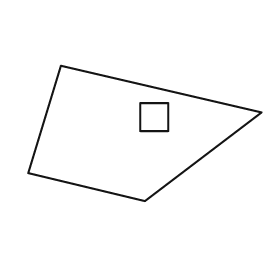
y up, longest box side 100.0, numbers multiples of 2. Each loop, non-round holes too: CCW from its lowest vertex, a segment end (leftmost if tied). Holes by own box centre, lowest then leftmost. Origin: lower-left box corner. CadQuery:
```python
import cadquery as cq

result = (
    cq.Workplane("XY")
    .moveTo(50.0, 0.0)
    .lineTo(100.0, 38.0)
    .lineTo(14.0, 58.0)
    .lineTo(0.0, 12.0)
    .close()
    .moveTo(48.0, 30.0)
    .lineTo(60.0, 30.0)
    .lineTo(60.0, 42.0)
    .lineTo(48.0, 42.0)
    .close()
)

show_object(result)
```